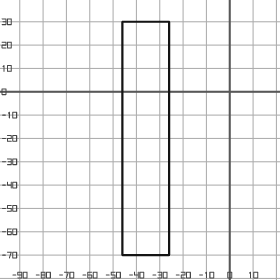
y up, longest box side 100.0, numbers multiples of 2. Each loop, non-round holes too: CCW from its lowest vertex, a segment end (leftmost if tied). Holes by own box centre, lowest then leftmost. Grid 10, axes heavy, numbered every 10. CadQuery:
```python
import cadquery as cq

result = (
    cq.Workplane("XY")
    .moveTo(-46.0, -70.0)
    .lineTo(-26.0, -70.0)
    .lineTo(-26.0, 30.0)
    .lineTo(-46.0, 30.0)
    .close()
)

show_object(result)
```